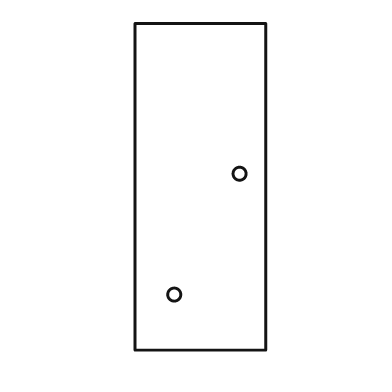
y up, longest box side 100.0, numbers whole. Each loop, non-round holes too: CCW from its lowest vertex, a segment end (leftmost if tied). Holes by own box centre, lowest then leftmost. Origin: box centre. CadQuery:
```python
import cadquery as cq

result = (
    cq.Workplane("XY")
    .moveTo(-20.0, -50.0)
    .lineTo(20.0, -50.0)
    .lineTo(20.0, 50.0)
    .lineTo(-20.0, 50.0)
    .close()
    .moveTo(-8.0, -33.0)
    .circle(2.0)
    .moveTo(12.0, 4.0)
    .circle(2.0)
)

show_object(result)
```